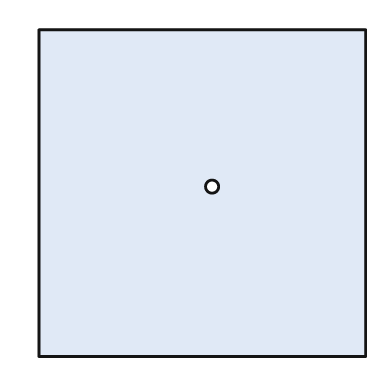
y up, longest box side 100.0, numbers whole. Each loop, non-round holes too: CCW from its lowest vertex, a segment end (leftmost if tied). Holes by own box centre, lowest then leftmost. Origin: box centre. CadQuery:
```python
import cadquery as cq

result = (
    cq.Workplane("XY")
    .moveTo(-50.0, -50.0)
    .lineTo(50.0, -50.0)
    .lineTo(50.0, 50.0)
    .lineTo(-50.0, 50.0)
    .close()
    .moveTo(3.0, 2.0)
    .circle(2.0)
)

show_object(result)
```